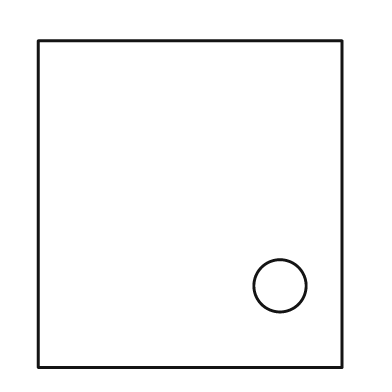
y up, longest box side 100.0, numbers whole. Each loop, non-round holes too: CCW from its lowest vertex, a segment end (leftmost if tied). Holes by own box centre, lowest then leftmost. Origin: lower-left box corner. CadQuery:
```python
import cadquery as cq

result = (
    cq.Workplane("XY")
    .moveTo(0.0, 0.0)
    .lineTo(93.0, 0.0)
    .lineTo(93.0, 100.0)
    .lineTo(0.0, 100.0)
    .close()
    .moveTo(74.0, 25.0)
    .circle(8.0)
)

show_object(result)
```